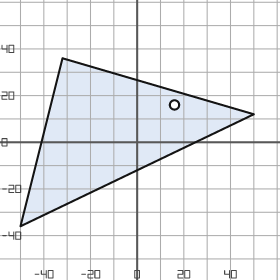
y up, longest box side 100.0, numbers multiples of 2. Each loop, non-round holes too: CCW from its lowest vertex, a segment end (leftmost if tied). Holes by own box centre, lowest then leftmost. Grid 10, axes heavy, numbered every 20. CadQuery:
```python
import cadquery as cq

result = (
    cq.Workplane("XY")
    .moveTo(-50.0, -36.0)
    .lineTo(50.0, 12.0)
    .lineTo(-32.0, 36.0)
    .close()
    .moveTo(16.0, 16.0)
    .circle(2.0)
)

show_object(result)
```